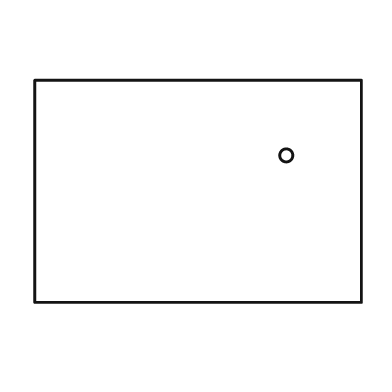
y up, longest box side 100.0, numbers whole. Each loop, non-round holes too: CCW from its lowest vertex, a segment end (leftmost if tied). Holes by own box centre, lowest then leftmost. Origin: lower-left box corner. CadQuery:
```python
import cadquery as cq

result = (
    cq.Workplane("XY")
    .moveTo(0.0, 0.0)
    .lineTo(100.0, 0.0)
    .lineTo(100.0, 68.0)
    .lineTo(0.0, 68.0)
    .close()
    .moveTo(77.0, 45.0)
    .circle(2.0)
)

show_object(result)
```